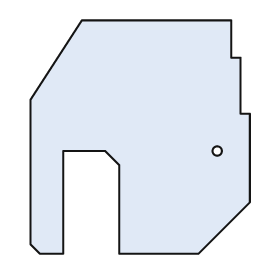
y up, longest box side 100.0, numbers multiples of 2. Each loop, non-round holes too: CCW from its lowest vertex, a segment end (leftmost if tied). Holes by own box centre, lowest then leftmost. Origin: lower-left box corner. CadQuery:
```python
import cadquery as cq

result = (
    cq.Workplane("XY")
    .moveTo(4.0, 0.0)
    .lineTo(14.0, 0.0)
    .lineTo(14.0, 44.0)
    .lineTo(32.0, 44.0)
    .lineTo(38.0, 38.0)
    .lineTo(38.0, 0.0)
    .lineTo(72.0, 0.0)
    .lineTo(94.0, 22.0)
    .lineTo(94.0, 60.0)
    .lineTo(90.0, 60.0)
    .lineTo(90.0, 84.0)
    .lineTo(86.0, 84.0)
    .lineTo(86.0, 100.0)
    .lineTo(22.0, 100.0)
    .lineTo(0.0, 66.0)
    .lineTo(0.0, 4.0)
    .close()
    .moveTo(80.0, 44.0)
    .circle(2.0)
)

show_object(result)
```